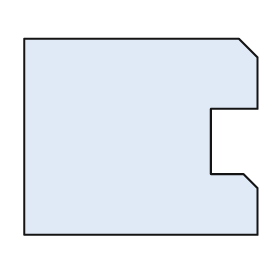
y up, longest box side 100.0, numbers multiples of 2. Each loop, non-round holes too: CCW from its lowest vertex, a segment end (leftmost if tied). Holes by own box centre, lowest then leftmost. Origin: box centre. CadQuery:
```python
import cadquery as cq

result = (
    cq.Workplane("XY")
    .moveTo(-50.0, -42.0)
    .lineTo(50.0, -42.0)
    .lineTo(50.0, -22.0)
    .lineTo(44.0, -16.0)
    .lineTo(30.0, -16.0)
    .lineTo(30.0, 12.0)
    .lineTo(50.0, 12.0)
    .lineTo(50.0, 34.0)
    .lineTo(42.0, 42.0)
    .lineTo(-50.0, 42.0)
    .close()
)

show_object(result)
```